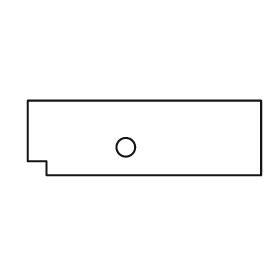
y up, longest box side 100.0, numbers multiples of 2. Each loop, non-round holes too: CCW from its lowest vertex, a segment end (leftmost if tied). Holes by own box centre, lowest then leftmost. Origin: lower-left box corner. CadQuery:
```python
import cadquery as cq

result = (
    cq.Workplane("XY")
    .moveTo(8.0, 0.0)
    .lineTo(100.0, 0.0)
    .lineTo(100.0, 32.0)
    .lineTo(0.0, 32.0)
    .lineTo(0.0, 6.0)
    .lineTo(8.0, 6.0)
    .close()
    .moveTo(42.0, 12.0)
    .circle(4.0)
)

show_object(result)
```